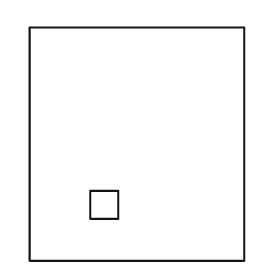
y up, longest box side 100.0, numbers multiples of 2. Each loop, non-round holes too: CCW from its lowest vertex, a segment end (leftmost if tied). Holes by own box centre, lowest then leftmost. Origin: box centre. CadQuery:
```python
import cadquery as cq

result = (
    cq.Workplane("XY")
    .moveTo(-46.0, -50.0)
    .lineTo(46.0, -50.0)
    .lineTo(46.0, 50.0)
    .lineTo(-46.0, 50.0)
    .close()
    .moveTo(-20.0, -32.0)
    .lineTo(-8.0, -32.0)
    .lineTo(-8.0, -20.0)
    .lineTo(-20.0, -20.0)
    .close()
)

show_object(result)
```